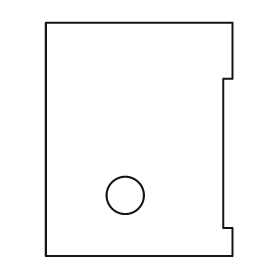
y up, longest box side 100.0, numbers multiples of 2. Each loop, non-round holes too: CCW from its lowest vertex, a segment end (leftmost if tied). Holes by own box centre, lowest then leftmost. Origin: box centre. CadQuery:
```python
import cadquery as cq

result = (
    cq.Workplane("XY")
    .moveTo(-40.0, -50.0)
    .lineTo(40.0, -50.0)
    .lineTo(40.0, -38.0)
    .lineTo(36.0, -38.0)
    .lineTo(36.0, 26.0)
    .lineTo(40.0, 26.0)
    .lineTo(40.0, 50.0)
    .lineTo(-40.0, 50.0)
    .close()
    .moveTo(-6.0, -24.0)
    .circle(8.0)
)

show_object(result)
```